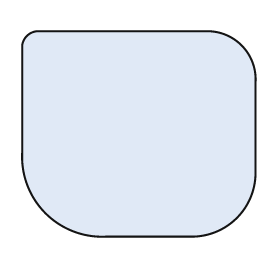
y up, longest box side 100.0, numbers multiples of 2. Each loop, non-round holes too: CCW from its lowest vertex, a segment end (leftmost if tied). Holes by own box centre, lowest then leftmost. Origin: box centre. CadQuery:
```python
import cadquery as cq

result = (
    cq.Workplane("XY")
    .moveTo(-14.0, -44.0)
    .lineTo(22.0, -44.0)
    .threePointArc((42.0, -36.0), (50.0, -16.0))
    .lineTo(50.0, 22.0)
    .threePointArc((44.0, 38.0), (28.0, 44.0))
    .lineTo(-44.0, 44.0)
    .threePointArc((-48.0, 42.0), (-50.0, 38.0))
    .lineTo(-50.0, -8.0)
    .threePointArc((-40.0, -34.0), (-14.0, -44.0))
    .close()
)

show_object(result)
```